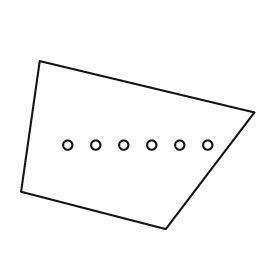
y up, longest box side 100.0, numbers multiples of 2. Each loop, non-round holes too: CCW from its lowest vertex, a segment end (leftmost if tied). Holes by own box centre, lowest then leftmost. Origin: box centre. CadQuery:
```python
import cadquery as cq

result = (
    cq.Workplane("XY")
    .moveTo(12.0, -36.0)
    .lineTo(50.0, 14.0)
    .lineTo(-42.0, 36.0)
    .lineTo(-50.0, -20.0)
    .close()
    .moveTo(-30.0, 0.0)
    .circle(2.0)
    .moveTo(-18.0, 0.0)
    .circle(2.0)
    .moveTo(-6.0, 0.0)
    .circle(2.0)
    .moveTo(6.0, 0.0)
    .circle(2.0)
    .moveTo(18.0, 0.0)
    .circle(2.0)
    .moveTo(30.0, 0.0)
    .circle(2.0)
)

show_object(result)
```